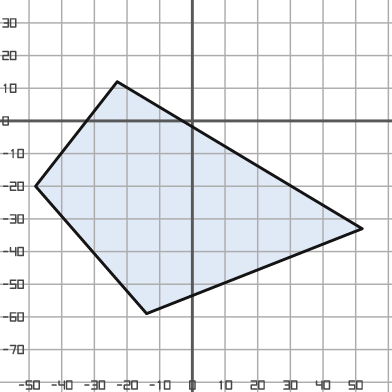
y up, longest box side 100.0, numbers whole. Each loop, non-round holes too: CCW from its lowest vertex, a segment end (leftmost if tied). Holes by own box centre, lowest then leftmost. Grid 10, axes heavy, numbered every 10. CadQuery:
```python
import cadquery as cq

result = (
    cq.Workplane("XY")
    .moveTo(-14.0, -59.0)
    .lineTo(52.0, -33.0)
    .lineTo(-23.0, 12.0)
    .lineTo(-48.0, -20.0)
    .close()
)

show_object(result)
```